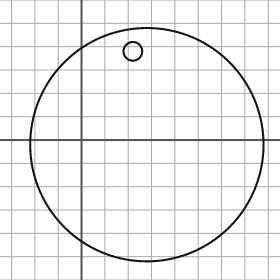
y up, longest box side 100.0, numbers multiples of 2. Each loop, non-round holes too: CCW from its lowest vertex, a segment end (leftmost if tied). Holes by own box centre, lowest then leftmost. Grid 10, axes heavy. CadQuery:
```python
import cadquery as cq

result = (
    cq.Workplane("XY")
    .moveTo(28.0, -2.0)
    .circle(50.0)
    .moveTo(22.0, 38.0)
    .circle(4.0)
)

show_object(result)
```